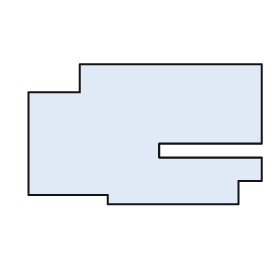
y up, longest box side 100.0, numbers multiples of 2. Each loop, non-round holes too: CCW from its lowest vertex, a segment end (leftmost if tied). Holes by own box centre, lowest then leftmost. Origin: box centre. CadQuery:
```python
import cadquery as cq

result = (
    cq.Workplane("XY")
    .moveTo(-16.0, -30.0)
    .lineTo(40.0, -30.0)
    .lineTo(40.0, -20.0)
    .lineTo(50.0, -20.0)
    .lineTo(50.0, -10.0)
    .lineTo(6.0, -10.0)
    .lineTo(6.0, -4.0)
    .lineTo(50.0, -4.0)
    .lineTo(50.0, 30.0)
    .lineTo(-28.0, 30.0)
    .lineTo(-28.0, 18.0)
    .lineTo(-50.0, 18.0)
    .lineTo(-50.0, -26.0)
    .lineTo(-16.0, -26.0)
    .close()
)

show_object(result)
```